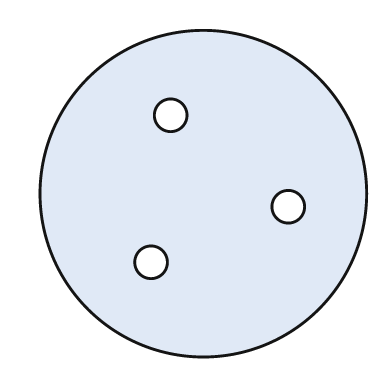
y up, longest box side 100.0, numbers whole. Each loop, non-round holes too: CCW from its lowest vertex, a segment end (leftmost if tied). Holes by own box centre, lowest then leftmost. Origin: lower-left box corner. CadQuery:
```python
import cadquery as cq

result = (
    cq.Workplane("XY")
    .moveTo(50.0, 50.0)
    .circle(50.0)
    .moveTo(34.0, 29.0)
    .circle(5.0)
    .moveTo(76.0, 46.0)
    .circle(5.0)
    .moveTo(40.0, 74.0)
    .circle(5.0)
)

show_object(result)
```